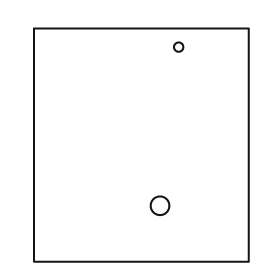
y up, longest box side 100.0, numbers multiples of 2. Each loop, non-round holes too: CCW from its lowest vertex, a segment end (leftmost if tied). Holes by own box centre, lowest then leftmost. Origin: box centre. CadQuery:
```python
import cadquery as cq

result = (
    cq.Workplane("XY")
    .moveTo(-46.0, -50.0)
    .lineTo(46.0, -50.0)
    .lineTo(46.0, 50.0)
    .lineTo(-46.0, 50.0)
    .close()
    .moveTo(8.0, -26.0)
    .circle(4.0)
    .moveTo(16.0, 42.0)
    .circle(2.0)
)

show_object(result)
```